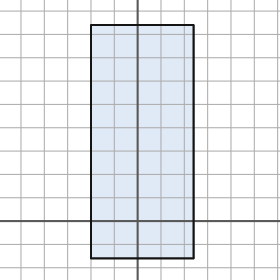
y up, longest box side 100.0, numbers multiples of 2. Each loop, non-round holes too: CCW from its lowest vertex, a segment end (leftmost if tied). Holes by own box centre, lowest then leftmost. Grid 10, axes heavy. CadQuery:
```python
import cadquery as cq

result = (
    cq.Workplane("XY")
    .moveTo(-20.0, -16.0)
    .lineTo(24.0, -16.0)
    .lineTo(24.0, 84.0)
    .lineTo(-20.0, 84.0)
    .close()
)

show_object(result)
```